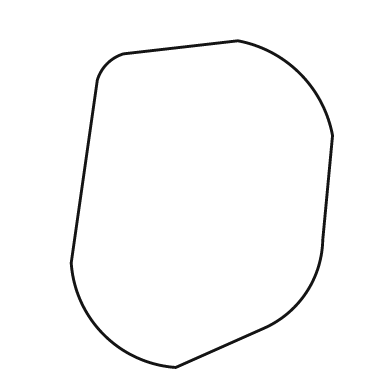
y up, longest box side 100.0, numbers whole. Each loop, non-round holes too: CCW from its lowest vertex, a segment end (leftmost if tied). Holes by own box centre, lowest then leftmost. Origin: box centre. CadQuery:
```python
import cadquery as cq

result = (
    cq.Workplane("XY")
    .moveTo(-8.0, -50.0)
    .lineTo(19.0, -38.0)
    .threePointArc((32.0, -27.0), (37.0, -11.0))
    .lineTo(40.0, 21.0)
    .threePointArc((30.0, 40.0), (11.0, 50.0))
    .lineTo(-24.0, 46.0)
    .threePointArc((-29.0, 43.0), (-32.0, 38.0))
    .lineTo(-40.0, -18.0)
    .threePointArc((-30.0, -40.0), (-8.0, -50.0))
    .close()
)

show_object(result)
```